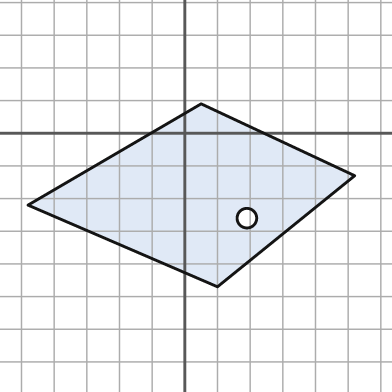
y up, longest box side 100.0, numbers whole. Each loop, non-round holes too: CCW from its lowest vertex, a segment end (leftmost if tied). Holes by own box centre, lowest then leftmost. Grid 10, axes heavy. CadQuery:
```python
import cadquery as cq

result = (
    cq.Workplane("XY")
    .moveTo(10.0, -47.0)
    .lineTo(52.0, -13.0)
    .lineTo(5.0, 9.0)
    .lineTo(-48.0, -22.0)
    .close()
    .moveTo(19.0, -26.0)
    .circle(3.0)
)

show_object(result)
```